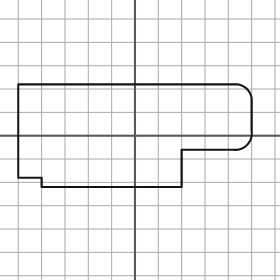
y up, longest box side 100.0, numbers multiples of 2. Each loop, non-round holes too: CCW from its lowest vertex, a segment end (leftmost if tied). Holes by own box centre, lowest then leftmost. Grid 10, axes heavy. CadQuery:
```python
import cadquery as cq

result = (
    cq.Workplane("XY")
    .moveTo(-40.0, -22.0)
    .lineTo(20.0, -22.0)
    .lineTo(20.0, -6.0)
    .lineTo(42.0, -6.0)
    .threePointArc((48.0, -4.0), (50.0, 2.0))
    .lineTo(50.0, 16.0)
    .threePointArc((48.0, 20.0), (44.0, 22.0))
    .lineTo(-50.0, 22.0)
    .lineTo(-50.0, -18.0)
    .lineTo(-40.0, -18.0)
    .close()
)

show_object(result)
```